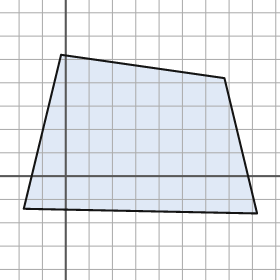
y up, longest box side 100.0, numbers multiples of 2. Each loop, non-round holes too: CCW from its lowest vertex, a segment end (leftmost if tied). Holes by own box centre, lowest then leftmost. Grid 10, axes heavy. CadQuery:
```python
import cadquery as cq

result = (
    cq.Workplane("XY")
    .moveTo(82.0, -16.0)
    .lineTo(68.0, 42.0)
    .lineTo(-2.0, 52.0)
    .lineTo(-18.0, -14.0)
    .close()
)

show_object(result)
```